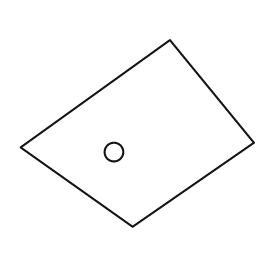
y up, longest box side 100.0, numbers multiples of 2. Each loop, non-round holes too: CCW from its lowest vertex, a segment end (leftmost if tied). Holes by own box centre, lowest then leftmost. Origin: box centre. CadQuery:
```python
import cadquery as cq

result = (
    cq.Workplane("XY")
    .moveTo(-2.0, -40.0)
    .lineTo(50.0, -4.0)
    .lineTo(14.0, 40.0)
    .lineTo(-50.0, -6.0)
    .close()
    .moveTo(-10.0, -8.0)
    .circle(4.0)
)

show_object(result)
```